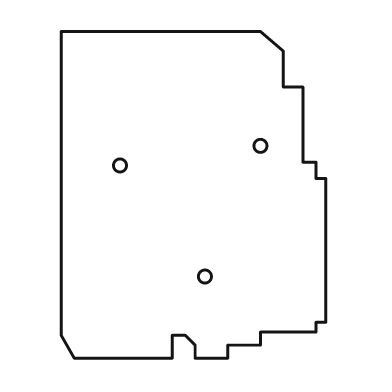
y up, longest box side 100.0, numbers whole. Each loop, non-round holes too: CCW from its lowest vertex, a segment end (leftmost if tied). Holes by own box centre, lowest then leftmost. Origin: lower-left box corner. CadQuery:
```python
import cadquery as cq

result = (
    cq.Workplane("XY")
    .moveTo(4.0, 0.0)
    .lineTo(34.0, 0.0)
    .lineTo(34.0, 7.0)
    .lineTo(38.0, 7.0)
    .lineTo(41.0, 4.0)
    .lineTo(41.0, 0.0)
    .lineTo(51.0, 0.0)
    .lineTo(51.0, 4.0)
    .lineTo(61.0, 4.0)
    .lineTo(61.0, 8.0)
    .lineTo(78.0, 8.0)
    .lineTo(78.0, 11.0)
    .lineTo(81.0, 11.0)
    .lineTo(81.0, 55.0)
    .lineTo(78.0, 55.0)
    .lineTo(78.0, 60.0)
    .lineTo(74.0, 60.0)
    .lineTo(74.0, 83.0)
    .lineTo(68.0, 83.0)
    .lineTo(68.0, 94.0)
    .lineTo(61.0, 100.0)
    .lineTo(0.0, 100.0)
    .lineTo(0.0, 7.0)
    .close()
    .moveTo(44.0, 25.0)
    .circle(2.0)
    .moveTo(18.0, 59.0)
    .circle(2.0)
    .moveTo(61.0, 65.0)
    .circle(2.0)
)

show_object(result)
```